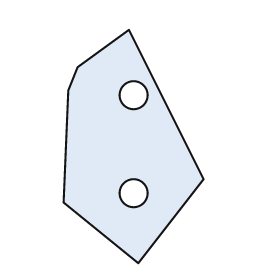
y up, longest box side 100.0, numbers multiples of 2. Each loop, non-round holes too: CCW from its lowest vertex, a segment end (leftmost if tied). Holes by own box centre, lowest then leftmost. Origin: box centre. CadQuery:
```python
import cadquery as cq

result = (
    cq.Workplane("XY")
    .moveTo(2.0, -50.0)
    .lineTo(30.0, -14.0)
    .lineTo(-2.0, 50.0)
    .lineTo(-24.0, 34.0)
    .lineTo(-28.0, 24.0)
    .lineTo(-30.0, -24.0)
    .close()
    .moveTo(0.0, -20.0)
    .circle(6.0)
    .moveTo(0.0, 22.0)
    .circle(6.0)
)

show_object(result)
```